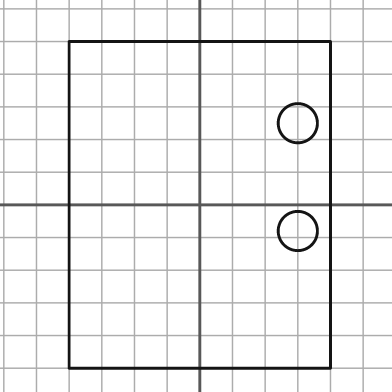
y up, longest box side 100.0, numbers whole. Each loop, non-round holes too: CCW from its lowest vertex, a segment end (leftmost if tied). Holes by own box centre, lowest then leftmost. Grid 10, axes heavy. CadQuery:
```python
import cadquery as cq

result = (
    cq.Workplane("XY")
    .moveTo(-40.0, -50.0)
    .lineTo(40.0, -50.0)
    .lineTo(40.0, 50.0)
    .lineTo(-40.0, 50.0)
    .close()
    .moveTo(30.0, -8.0)
    .circle(6.0)
    .moveTo(30.0, 25.0)
    .circle(6.0)
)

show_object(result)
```